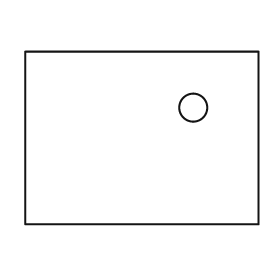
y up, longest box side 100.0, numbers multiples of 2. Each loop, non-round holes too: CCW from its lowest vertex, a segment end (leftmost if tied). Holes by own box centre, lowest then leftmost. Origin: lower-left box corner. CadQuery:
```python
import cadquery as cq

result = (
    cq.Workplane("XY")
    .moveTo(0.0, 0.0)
    .lineTo(100.0, 0.0)
    .lineTo(100.0, 74.0)
    .lineTo(0.0, 74.0)
    .close()
    .moveTo(72.0, 50.0)
    .circle(6.0)
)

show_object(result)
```